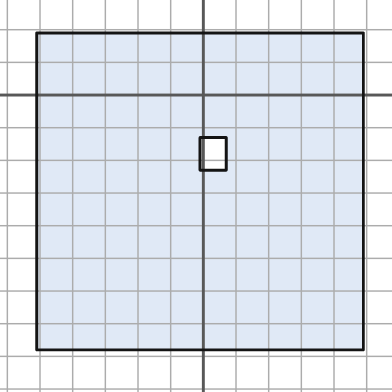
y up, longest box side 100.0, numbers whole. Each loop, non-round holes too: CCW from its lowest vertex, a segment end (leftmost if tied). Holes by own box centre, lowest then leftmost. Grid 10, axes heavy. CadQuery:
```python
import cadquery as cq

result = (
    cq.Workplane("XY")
    .moveTo(-51.0, -78.0)
    .lineTo(49.0, -78.0)
    .lineTo(49.0, 19.0)
    .lineTo(-51.0, 19.0)
    .close()
    .moveTo(-1.0, -23.0)
    .lineTo(7.0, -23.0)
    .lineTo(7.0, -13.0)
    .lineTo(-1.0, -13.0)
    .close()
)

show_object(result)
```